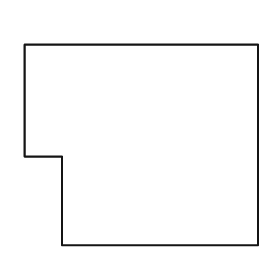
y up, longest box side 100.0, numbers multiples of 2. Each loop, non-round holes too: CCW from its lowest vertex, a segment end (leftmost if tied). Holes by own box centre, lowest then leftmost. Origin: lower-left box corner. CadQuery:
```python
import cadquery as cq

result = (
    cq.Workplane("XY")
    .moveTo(16.0, 0.0)
    .lineTo(100.0, 0.0)
    .lineTo(100.0, 86.0)
    .lineTo(0.0, 86.0)
    .lineTo(0.0, 38.0)
    .lineTo(16.0, 38.0)
    .close()
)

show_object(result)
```